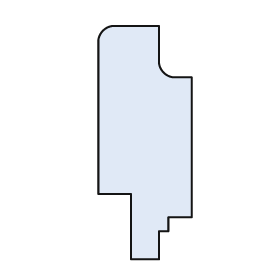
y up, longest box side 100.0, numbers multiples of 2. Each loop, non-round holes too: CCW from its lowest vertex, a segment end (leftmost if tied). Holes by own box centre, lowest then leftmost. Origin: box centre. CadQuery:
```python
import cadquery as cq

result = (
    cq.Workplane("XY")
    .moveTo(-6.0, -50.0)
    .lineTo(6.0, -50.0)
    .lineTo(6.0, -38.0)
    .lineTo(10.0, -38.0)
    .lineTo(10.0, -32.0)
    .lineTo(20.0, -32.0)
    .lineTo(20.0, 28.0)
    .lineTo(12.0, 28.0)
    .threePointArc((8.0, 30.0), (6.0, 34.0))
    .lineTo(6.0, 50.0)
    .lineTo(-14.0, 50.0)
    .threePointArc((-18.0, 48.0), (-20.0, 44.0))
    .lineTo(-20.0, -22.0)
    .lineTo(-6.0, -22.0)
    .close()
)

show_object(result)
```